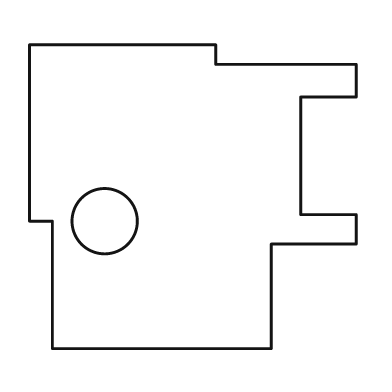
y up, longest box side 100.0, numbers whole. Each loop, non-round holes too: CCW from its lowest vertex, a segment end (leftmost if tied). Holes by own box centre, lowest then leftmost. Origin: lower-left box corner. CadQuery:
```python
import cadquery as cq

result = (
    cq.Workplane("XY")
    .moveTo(7.0, 0.0)
    .lineTo(74.0, 0.0)
    .lineTo(74.0, 32.0)
    .lineTo(100.0, 32.0)
    .lineTo(100.0, 41.0)
    .lineTo(83.0, 41.0)
    .lineTo(83.0, 77.0)
    .lineTo(100.0, 77.0)
    .lineTo(100.0, 87.0)
    .lineTo(57.0, 87.0)
    .lineTo(57.0, 93.0)
    .lineTo(0.0, 93.0)
    .lineTo(0.0, 39.0)
    .lineTo(7.0, 39.0)
    .close()
    .moveTo(23.0, 39.0)
    .circle(10.0)
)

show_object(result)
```